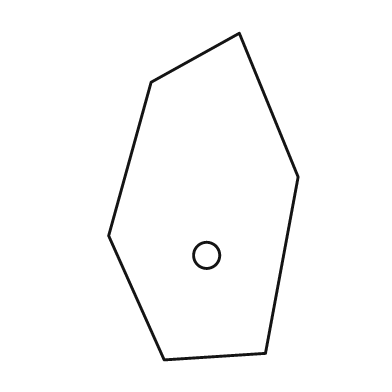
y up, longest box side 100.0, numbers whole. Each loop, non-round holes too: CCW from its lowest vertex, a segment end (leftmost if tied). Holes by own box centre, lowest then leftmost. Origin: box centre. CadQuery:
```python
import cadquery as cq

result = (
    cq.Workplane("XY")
    .moveTo(-12.0, -50.0)
    .lineTo(19.0, -48.0)
    .lineTo(29.0, 6.0)
    .lineTo(11.0, 50.0)
    .lineTo(-16.0, 35.0)
    .lineTo(-29.0, -12.0)
    .close()
    .moveTo(1.0, -18.0)
    .circle(4.0)
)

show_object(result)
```